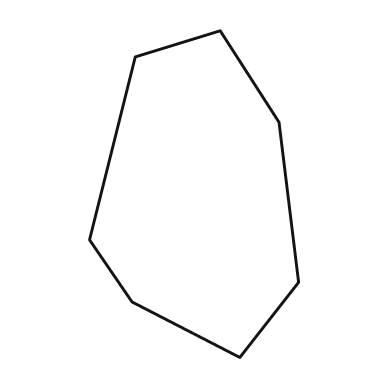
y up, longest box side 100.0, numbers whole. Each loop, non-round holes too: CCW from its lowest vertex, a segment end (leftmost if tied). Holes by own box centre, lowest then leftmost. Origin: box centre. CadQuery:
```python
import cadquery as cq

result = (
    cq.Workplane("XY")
    .moveTo(14.0, -50.0)
    .lineTo(32.0, -27.0)
    .lineTo(26.0, 22.0)
    .lineTo(8.0, 50.0)
    .lineTo(-18.0, 42.0)
    .lineTo(-32.0, -14.0)
    .lineTo(-19.0, -33.0)
    .close()
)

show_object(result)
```